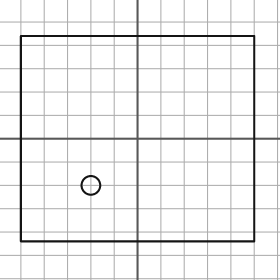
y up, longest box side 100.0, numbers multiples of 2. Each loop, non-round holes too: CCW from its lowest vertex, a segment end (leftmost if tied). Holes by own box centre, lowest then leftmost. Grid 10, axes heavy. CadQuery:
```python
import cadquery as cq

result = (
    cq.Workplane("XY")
    .moveTo(-50.0, -44.0)
    .lineTo(50.0, -44.0)
    .lineTo(50.0, 44.0)
    .lineTo(-50.0, 44.0)
    .close()
    .moveTo(-20.0, -20.0)
    .circle(4.0)
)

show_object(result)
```